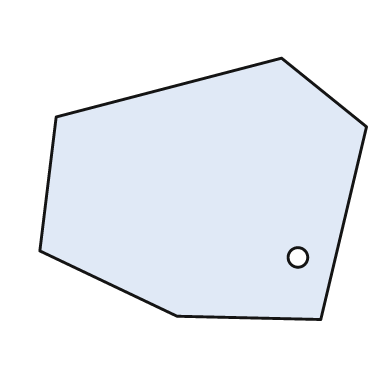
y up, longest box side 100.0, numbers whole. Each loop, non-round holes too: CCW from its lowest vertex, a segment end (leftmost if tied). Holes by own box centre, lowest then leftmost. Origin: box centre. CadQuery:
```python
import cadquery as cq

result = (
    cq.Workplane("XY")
    .moveTo(36.0, -40.0)
    .lineTo(50.0, 19.0)
    .lineTo(24.0, 40.0)
    .lineTo(-45.0, 22.0)
    .lineTo(-50.0, -19.0)
    .lineTo(-8.0, -39.0)
    .close()
    .moveTo(29.0, -21.0)
    .circle(3.0)
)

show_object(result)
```